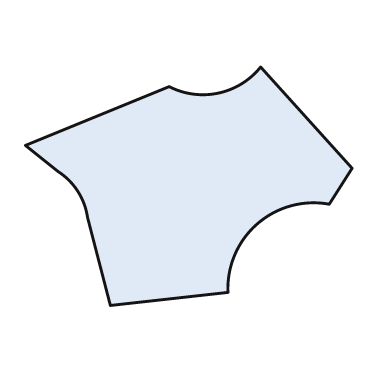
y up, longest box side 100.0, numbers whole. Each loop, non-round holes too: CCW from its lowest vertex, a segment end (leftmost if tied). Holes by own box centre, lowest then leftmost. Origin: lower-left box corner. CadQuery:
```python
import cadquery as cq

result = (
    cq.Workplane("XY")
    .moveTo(26.0, 0.0)
    .lineTo(62.0, 4.0)
    .threePointArc((71.0, 25.0), (93.0, 31.0))
    .lineTo(100.0, 42.0)
    .lineTo(72.0, 73.0)
    .threePointArc((59.0, 65.0), (44.0, 67.0))
    .lineTo(0.0, 49.0)
    .lineTo(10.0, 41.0)
    .threePointArc((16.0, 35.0), (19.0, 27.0))
    .close()
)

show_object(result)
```